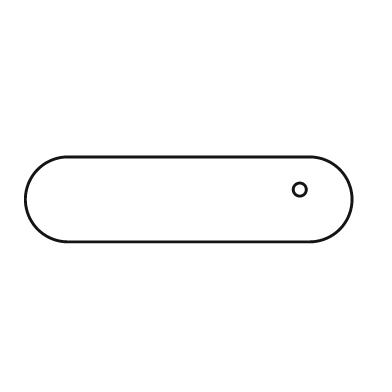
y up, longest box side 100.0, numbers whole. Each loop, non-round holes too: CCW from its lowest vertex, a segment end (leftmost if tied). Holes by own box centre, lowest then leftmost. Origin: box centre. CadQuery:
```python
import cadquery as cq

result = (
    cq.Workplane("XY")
    .moveTo(-37.0, -13.0)
    .lineTo(37.0, -13.0)
    .threePointArc((50.0, 0.0), (37.0, 13.0))
    .lineTo(-37.0, 13.0)
    .threePointArc((-50.0, 0.0), (-37.0, -13.0))
    .close()
    .moveTo(34.0, 3.0)
    .circle(2.0)
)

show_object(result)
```